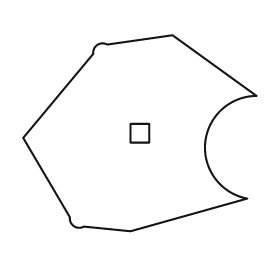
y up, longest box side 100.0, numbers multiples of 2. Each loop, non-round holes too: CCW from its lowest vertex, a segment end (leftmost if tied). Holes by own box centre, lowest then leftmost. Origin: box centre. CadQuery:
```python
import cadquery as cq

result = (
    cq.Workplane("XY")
    .moveTo(-4.0, -42.0)
    .lineTo(46.0, -28.0)
    .threePointArc((28.0, -4.0), (50.0, 16.0))
    .lineTo(14.0, 42.0)
    .lineTo(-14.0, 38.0)
    .threePointArc((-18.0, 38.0), (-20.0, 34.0))
    .lineTo(-50.0, -2.0)
    .lineTo(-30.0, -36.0)
    .threePointArc((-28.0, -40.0), (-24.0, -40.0))
    .close()
    .moveTo(-4.0, -4.0)
    .lineTo(4.0, -4.0)
    .lineTo(4.0, 4.0)
    .lineTo(-4.0, 4.0)
    .close()
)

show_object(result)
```